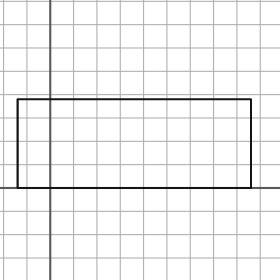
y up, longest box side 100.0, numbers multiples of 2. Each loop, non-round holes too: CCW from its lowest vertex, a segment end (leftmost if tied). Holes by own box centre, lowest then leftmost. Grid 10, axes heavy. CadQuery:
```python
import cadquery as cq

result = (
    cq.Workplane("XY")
    .moveTo(-14.0, 0.0)
    .lineTo(86.0, 0.0)
    .lineTo(86.0, 38.0)
    .lineTo(-14.0, 38.0)
    .close()
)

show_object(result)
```